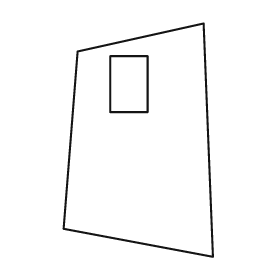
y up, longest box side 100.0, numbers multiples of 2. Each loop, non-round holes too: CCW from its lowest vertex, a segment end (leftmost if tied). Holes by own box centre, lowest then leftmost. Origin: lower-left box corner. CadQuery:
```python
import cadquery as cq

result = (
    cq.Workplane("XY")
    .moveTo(64.0, 0.0)
    .lineTo(60.0, 100.0)
    .lineTo(6.0, 88.0)
    .lineTo(0.0, 12.0)
    .close()
    .moveTo(20.0, 62.0)
    .lineTo(36.0, 62.0)
    .lineTo(36.0, 86.0)
    .lineTo(20.0, 86.0)
    .close()
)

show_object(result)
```